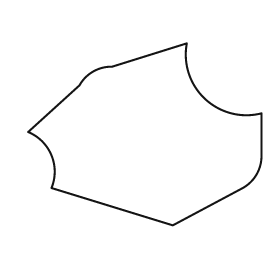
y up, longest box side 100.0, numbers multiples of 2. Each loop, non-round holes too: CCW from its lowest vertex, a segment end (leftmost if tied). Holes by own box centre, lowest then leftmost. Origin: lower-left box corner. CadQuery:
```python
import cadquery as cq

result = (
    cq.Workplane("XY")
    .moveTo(62.0, 0.0)
    .lineTo(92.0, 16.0)
    .threePointArc((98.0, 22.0), (100.0, 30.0))
    .lineTo(100.0, 48.0)
    .threePointArc((76.0, 54.0), (68.0, 78.0))
    .lineTo(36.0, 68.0)
    .threePointArc((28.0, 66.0), (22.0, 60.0))
    .lineTo(0.0, 40.0)
    .threePointArc((10.0, 30.0), (10.0, 16.0))
    .close()
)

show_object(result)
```